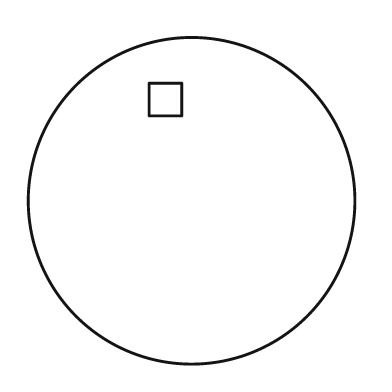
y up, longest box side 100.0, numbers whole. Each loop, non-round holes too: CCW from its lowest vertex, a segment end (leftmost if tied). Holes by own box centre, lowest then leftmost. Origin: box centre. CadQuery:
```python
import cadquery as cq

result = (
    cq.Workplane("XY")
    .moveTo(0.0, 0.0)
    .circle(50.0)
    .moveTo(-13.0, 26.0)
    .lineTo(-3.0, 26.0)
    .lineTo(-3.0, 36.0)
    .lineTo(-13.0, 36.0)
    .close()
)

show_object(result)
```